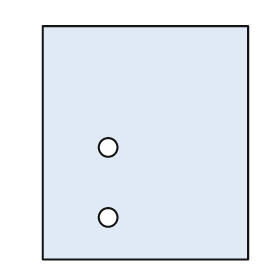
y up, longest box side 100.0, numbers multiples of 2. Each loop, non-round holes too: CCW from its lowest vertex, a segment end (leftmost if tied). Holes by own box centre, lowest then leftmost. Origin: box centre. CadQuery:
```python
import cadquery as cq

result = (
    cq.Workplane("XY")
    .moveTo(-44.0, -50.0)
    .lineTo(44.0, -50.0)
    .lineTo(44.0, 50.0)
    .lineTo(-44.0, 50.0)
    .close()
    .moveTo(-16.0, -32.0)
    .circle(4.0)
    .moveTo(-16.0, -2.0)
    .circle(4.0)
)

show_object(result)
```